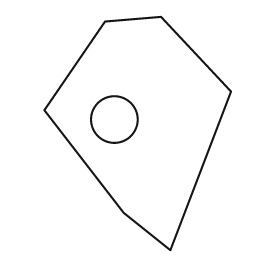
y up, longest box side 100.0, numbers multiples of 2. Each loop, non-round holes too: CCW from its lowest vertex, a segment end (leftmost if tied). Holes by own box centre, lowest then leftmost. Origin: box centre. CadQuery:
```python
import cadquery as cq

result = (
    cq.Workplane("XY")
    .moveTo(14.0, -50.0)
    .lineTo(40.0, 18.0)
    .lineTo(10.0, 50.0)
    .lineTo(-14.0, 48.0)
    .lineTo(-40.0, 10.0)
    .lineTo(-6.0, -34.0)
    .close()
    .moveTo(-10.0, 6.0)
    .circle(10.0)
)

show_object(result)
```